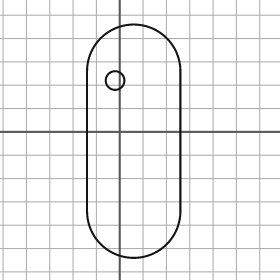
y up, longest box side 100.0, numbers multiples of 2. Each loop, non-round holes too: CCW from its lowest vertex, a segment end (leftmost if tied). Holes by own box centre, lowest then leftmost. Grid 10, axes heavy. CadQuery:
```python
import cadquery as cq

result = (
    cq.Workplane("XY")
    .moveTo(-14.0, -34.0)
    .threePointArc((6.0, -54.0), (26.0, -34.0))
    .lineTo(26.0, 26.0)
    .threePointArc((6.0, 46.0), (-14.0, 26.0))
    .close()
    .moveTo(-2.0, 22.0)
    .circle(4.0)
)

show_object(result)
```